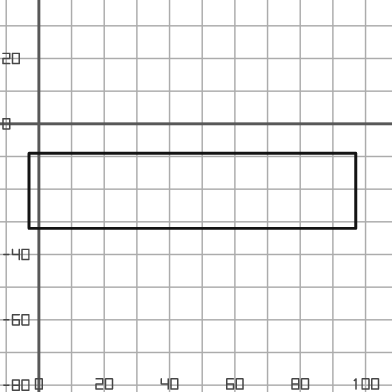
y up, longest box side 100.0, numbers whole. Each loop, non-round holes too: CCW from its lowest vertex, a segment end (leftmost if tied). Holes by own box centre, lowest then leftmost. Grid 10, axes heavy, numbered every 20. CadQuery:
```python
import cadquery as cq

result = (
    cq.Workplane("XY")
    .moveTo(-3.0, -32.0)
    .lineTo(97.0, -32.0)
    .lineTo(97.0, -9.0)
    .lineTo(-3.0, -9.0)
    .close()
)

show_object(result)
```